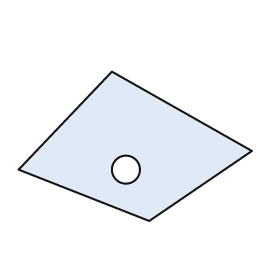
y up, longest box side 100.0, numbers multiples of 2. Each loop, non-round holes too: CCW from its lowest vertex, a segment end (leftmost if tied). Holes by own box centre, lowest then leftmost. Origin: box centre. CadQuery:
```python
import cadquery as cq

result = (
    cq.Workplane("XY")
    .moveTo(6.0, -32.0)
    .lineTo(50.0, -2.0)
    .lineTo(-10.0, 32.0)
    .lineTo(-50.0, -10.0)
    .close()
    .moveTo(-4.0, -10.0)
    .circle(6.0)
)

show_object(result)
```